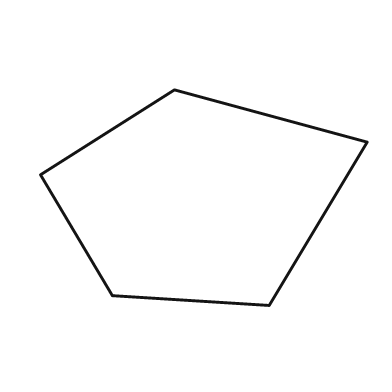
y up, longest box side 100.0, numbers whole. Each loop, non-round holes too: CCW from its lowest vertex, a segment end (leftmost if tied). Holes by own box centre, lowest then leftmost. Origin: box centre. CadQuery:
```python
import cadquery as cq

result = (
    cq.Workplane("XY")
    .moveTo(20.0, -33.0)
    .lineTo(50.0, 17.0)
    .lineTo(-9.0, 33.0)
    .lineTo(-50.0, 7.0)
    .lineTo(-28.0, -30.0)
    .close()
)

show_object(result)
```